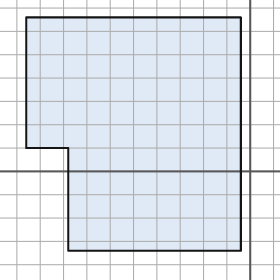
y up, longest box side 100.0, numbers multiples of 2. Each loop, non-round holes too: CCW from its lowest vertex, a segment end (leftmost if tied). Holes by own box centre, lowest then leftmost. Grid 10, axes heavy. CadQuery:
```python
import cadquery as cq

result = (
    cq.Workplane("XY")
    .moveTo(-78.0, -34.0)
    .lineTo(-4.0, -34.0)
    .lineTo(-4.0, 66.0)
    .lineTo(-96.0, 66.0)
    .lineTo(-96.0, 10.0)
    .lineTo(-78.0, 10.0)
    .close()
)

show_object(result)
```